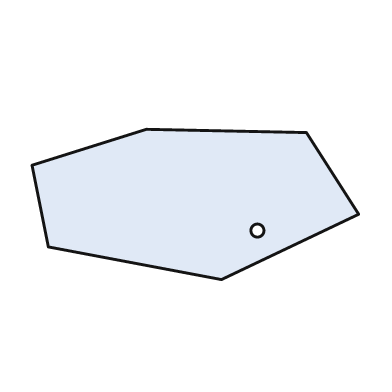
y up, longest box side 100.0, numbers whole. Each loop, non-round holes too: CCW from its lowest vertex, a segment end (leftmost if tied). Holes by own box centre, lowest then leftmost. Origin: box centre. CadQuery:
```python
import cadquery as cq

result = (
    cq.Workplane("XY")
    .moveTo(8.0, -23.0)
    .lineTo(50.0, -3.0)
    .lineTo(34.0, 22.0)
    .lineTo(-15.0, 23.0)
    .lineTo(-50.0, 12.0)
    .lineTo(-45.0, -13.0)
    .close()
    .moveTo(19.0, -8.0)
    .circle(2.0)
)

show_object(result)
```